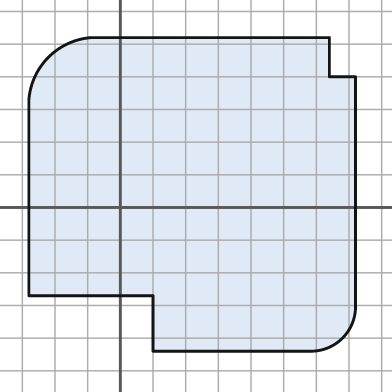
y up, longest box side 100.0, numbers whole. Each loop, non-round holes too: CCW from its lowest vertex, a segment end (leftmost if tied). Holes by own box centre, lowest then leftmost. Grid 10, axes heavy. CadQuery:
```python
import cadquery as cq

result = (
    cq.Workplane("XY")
    .moveTo(10.0, -44.0)
    .lineTo(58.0, -44.0)
    .threePointArc((68.0, -40.0), (72.0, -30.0))
    .lineTo(72.0, 40.0)
    .lineTo(64.0, 40.0)
    .lineTo(64.0, 52.0)
    .lineTo(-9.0, 52.0)
    .threePointArc((-22.0, 46.0), (-28.0, 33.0))
    .lineTo(-28.0, -27.0)
    .lineTo(10.0, -27.0)
    .close()
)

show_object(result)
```